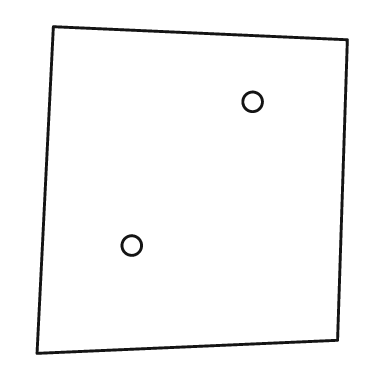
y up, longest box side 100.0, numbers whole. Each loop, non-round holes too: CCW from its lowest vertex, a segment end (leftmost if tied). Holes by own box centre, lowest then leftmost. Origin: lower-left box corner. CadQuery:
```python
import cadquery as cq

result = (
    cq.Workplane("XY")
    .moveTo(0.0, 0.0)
    .lineTo(92.0, 4.0)
    .lineTo(95.0, 96.0)
    .lineTo(5.0, 100.0)
    .close()
    .moveTo(29.0, 33.0)
    .circle(3.0)
    .moveTo(66.0, 77.0)
    .circle(3.0)
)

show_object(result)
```